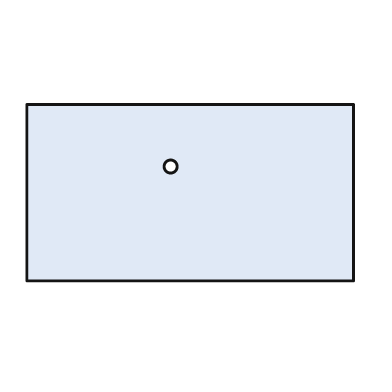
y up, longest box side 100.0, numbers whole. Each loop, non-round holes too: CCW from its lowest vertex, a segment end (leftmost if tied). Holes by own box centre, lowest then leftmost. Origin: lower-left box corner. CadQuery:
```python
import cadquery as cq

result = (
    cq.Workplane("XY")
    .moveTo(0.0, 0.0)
    .lineTo(100.0, 0.0)
    .lineTo(100.0, 54.0)
    .lineTo(0.0, 54.0)
    .close()
    .moveTo(44.0, 35.0)
    .circle(2.0)
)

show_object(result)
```